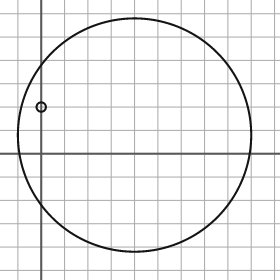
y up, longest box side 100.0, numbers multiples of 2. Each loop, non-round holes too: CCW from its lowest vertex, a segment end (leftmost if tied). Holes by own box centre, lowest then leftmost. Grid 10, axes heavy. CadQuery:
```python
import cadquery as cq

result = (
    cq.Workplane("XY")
    .moveTo(40.0, 8.0)
    .circle(50.0)
    .moveTo(0.0, 20.0)
    .circle(2.0)
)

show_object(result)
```